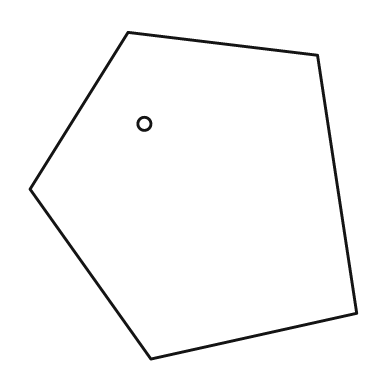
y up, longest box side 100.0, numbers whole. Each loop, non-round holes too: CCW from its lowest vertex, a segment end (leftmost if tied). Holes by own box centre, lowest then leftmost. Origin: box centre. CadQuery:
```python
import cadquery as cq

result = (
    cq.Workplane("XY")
    .moveTo(-13.0, -50.0)
    .lineTo(50.0, -36.0)
    .lineTo(38.0, 43.0)
    .lineTo(-20.0, 50.0)
    .lineTo(-50.0, 2.0)
    .close()
    .moveTo(-15.0, 22.0)
    .circle(2.0)
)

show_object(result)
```